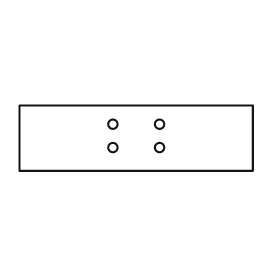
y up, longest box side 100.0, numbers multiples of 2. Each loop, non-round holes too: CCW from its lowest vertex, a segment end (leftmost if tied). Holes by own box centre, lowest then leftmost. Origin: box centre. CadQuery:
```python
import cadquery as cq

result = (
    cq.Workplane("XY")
    .moveTo(-50.0, -14.0)
    .lineTo(50.0, -14.0)
    .lineTo(50.0, 14.0)
    .lineTo(-50.0, 14.0)
    .close()
    .moveTo(-10.0, -4.0)
    .circle(2.0)
    .moveTo(10.0, -4.0)
    .circle(2.0)
    .moveTo(-10.0, 6.0)
    .circle(2.0)
    .moveTo(10.0, 6.0)
    .circle(2.0)
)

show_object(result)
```